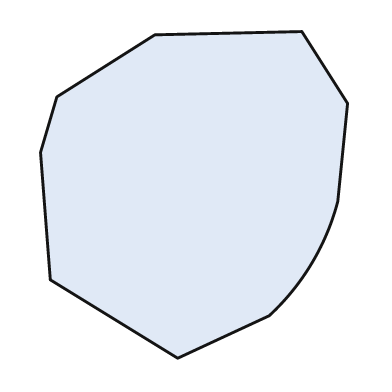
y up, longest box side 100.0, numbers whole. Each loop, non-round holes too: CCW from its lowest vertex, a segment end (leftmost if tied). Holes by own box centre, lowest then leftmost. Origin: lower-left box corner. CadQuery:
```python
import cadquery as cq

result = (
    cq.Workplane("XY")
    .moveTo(42.0, 0.0)
    .lineTo(70.0, 13.0)
    .threePointArc((83.0, 29.0), (91.0, 48.0))
    .lineTo(94.0, 78.0)
    .lineTo(80.0, 100.0)
    .lineTo(35.0, 99.0)
    .lineTo(5.0, 80.0)
    .lineTo(0.0, 63.0)
    .lineTo(3.0, 24.0)
    .close()
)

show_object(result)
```